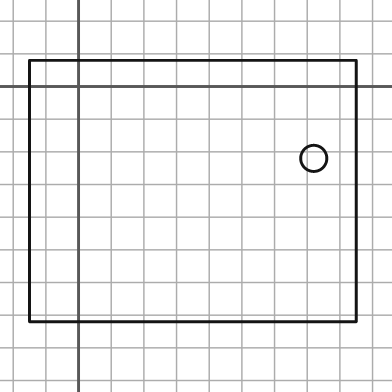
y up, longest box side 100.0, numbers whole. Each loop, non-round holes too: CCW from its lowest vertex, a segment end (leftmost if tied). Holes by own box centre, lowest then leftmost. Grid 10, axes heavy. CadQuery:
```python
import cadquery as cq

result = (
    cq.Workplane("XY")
    .moveTo(-15.0, -72.0)
    .lineTo(85.0, -72.0)
    .lineTo(85.0, 8.0)
    .lineTo(-15.0, 8.0)
    .close()
    .moveTo(72.0, -22.0)
    .circle(4.0)
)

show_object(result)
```